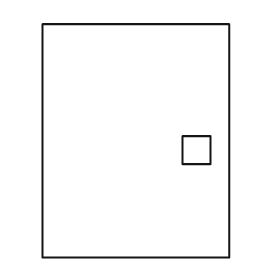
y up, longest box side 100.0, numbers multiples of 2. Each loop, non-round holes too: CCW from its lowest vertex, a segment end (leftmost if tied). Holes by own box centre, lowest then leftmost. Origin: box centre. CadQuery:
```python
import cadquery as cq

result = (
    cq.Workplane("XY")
    .moveTo(-40.0, -50.0)
    .lineTo(40.0, -50.0)
    .lineTo(40.0, 50.0)
    .lineTo(-40.0, 50.0)
    .close()
    .moveTo(20.0, -10.0)
    .lineTo(32.0, -10.0)
    .lineTo(32.0, 2.0)
    .lineTo(20.0, 2.0)
    .close()
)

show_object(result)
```